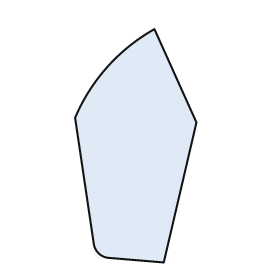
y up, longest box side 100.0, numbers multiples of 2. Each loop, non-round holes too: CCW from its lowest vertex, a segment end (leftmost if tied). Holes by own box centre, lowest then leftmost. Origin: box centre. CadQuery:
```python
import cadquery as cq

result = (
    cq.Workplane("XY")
    .moveTo(12.0, -50.0)
    .lineTo(26.0, 10.0)
    .lineTo(8.0, 50.0)
    .threePointArc((-12.0, 34.0), (-26.0, 12.0))
    .lineTo(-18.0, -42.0)
    .threePointArc((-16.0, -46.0), (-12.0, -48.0))
    .close()
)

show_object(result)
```